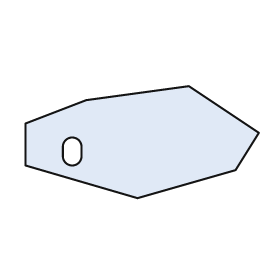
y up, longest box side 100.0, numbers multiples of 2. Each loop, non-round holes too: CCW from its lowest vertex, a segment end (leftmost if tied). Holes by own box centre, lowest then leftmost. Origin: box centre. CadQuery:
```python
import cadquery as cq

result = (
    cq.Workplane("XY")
    .moveTo(-2.0, -24.0)
    .lineTo(40.0, -12.0)
    .lineTo(50.0, 4.0)
    .lineTo(20.0, 24.0)
    .lineTo(-24.0, 18.0)
    .lineTo(-50.0, 8.0)
    .lineTo(-50.0, -10.0)
    .close()
    .moveTo(-34.0, -6.0)
    .threePointArc((-30.0, -10.0), (-26.0, -6.0))
    .lineTo(-26.0, -2.0)
    .threePointArc((-30.0, 2.0), (-34.0, -2.0))
    .close()
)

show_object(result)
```